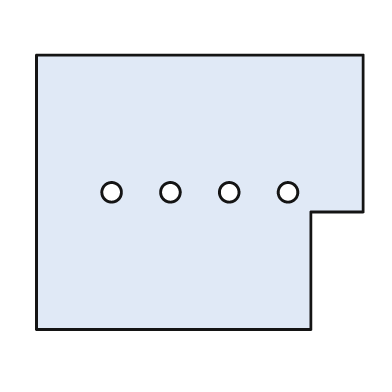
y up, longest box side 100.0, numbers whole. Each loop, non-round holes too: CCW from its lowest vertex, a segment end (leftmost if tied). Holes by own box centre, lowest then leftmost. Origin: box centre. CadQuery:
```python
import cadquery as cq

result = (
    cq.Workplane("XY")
    .moveTo(-50.0, -42.0)
    .lineTo(34.0, -42.0)
    .lineTo(34.0, -6.0)
    .lineTo(50.0, -6.0)
    .lineTo(50.0, 42.0)
    .lineTo(-50.0, 42.0)
    .close()
    .moveTo(-27.0, 0.0)
    .circle(3.0)
    .moveTo(-9.0, 0.0)
    .circle(3.0)
    .moveTo(9.0, 0.0)
    .circle(3.0)
    .moveTo(27.0, 0.0)
    .circle(3.0)
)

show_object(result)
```